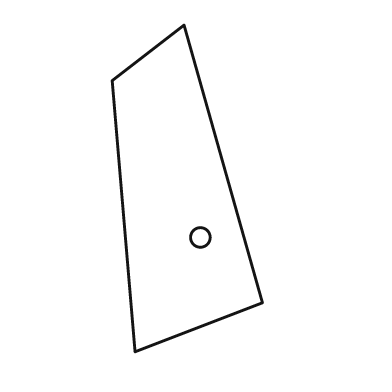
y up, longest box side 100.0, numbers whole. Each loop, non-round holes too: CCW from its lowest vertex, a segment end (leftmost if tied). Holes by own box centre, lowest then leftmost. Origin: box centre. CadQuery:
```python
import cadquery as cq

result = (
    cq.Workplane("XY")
    .moveTo(-16.0, -50.0)
    .lineTo(23.0, -35.0)
    .lineTo(-1.0, 50.0)
    .lineTo(-23.0, 33.0)
    .close()
    .moveTo(4.0, -15.0)
    .circle(3.0)
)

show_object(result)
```